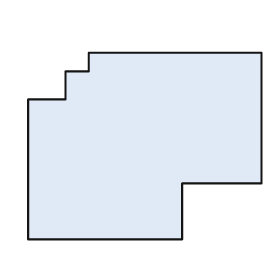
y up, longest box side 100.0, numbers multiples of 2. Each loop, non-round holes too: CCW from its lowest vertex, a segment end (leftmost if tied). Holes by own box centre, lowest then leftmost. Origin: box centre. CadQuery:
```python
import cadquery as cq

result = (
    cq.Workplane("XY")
    .moveTo(-50.0, -40.0)
    .lineTo(16.0, -40.0)
    .lineTo(16.0, -16.0)
    .lineTo(50.0, -16.0)
    .lineTo(50.0, 40.0)
    .lineTo(-24.0, 40.0)
    .lineTo(-24.0, 32.0)
    .lineTo(-34.0, 32.0)
    .lineTo(-34.0, 20.0)
    .lineTo(-50.0, 20.0)
    .close()
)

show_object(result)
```